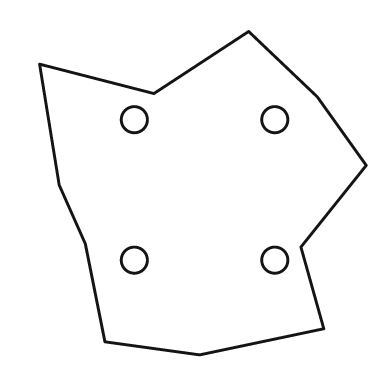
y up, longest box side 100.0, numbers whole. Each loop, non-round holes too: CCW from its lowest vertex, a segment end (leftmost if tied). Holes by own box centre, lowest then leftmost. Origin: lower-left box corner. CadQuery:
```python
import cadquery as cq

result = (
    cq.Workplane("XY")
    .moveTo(49.0, 0.0)
    .lineTo(87.0, 8.0)
    .lineTo(80.0, 33.0)
    .lineTo(100.0, 58.0)
    .lineTo(85.0, 79.0)
    .lineTo(64.0, 99.0)
    .lineTo(35.0, 80.0)
    .lineTo(0.0, 89.0)
    .lineTo(6.0, 52.0)
    .lineTo(14.0, 34.0)
    .lineTo(20.0, 4.0)
    .close()
    .moveTo(29.0, 29.0)
    .circle(4.0)
    .moveTo(72.0, 29.0)
    .circle(4.0)
    .moveTo(29.0, 72.0)
    .circle(4.0)
    .moveTo(72.0, 72.0)
    .circle(4.0)
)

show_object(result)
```